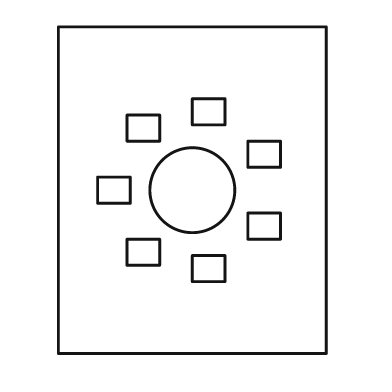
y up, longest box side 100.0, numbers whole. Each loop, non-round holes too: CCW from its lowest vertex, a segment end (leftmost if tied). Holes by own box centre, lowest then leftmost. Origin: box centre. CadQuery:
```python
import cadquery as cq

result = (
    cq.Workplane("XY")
    .moveTo(-41.0, -50.0)
    .lineTo(41.0, -50.0)
    .lineTo(41.0, 50.0)
    .lineTo(-41.0, 50.0)
    .close()
    .moveTo(0.0, -28.0)
    .lineTo(10.0, -28.0)
    .lineTo(10.0, -20.0)
    .lineTo(0.0, -20.0)
    .close()
    .moveTo(-20.0, -23.0)
    .lineTo(-10.0, -23.0)
    .lineTo(-10.0, -15.0)
    .lineTo(-20.0, -15.0)
    .close()
    .moveTo(17.0, -15.0)
    .lineTo(27.0, -15.0)
    .lineTo(27.0, -7.0)
    .lineTo(17.0, -7.0)
    .close()
    .moveTo(-29.0, -4.0)
    .lineTo(-19.0, -4.0)
    .lineTo(-19.0, 4.0)
    .lineTo(-29.0, 4.0)
    .close()
    .moveTo(0.0, 0.0)
    .circle(13.0)
    .moveTo(17.0, 7.0)
    .lineTo(27.0, 7.0)
    .lineTo(27.0, 15.0)
    .lineTo(17.0, 15.0)
    .close()
    .moveTo(-20.0, 15.0)
    .lineTo(-10.0, 15.0)
    .lineTo(-10.0, 23.0)
    .lineTo(-20.0, 23.0)
    .close()
    .moveTo(0.0, 20.0)
    .lineTo(10.0, 20.0)
    .lineTo(10.0, 28.0)
    .lineTo(0.0, 28.0)
    .close()
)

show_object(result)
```